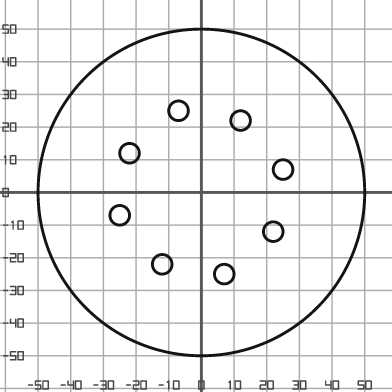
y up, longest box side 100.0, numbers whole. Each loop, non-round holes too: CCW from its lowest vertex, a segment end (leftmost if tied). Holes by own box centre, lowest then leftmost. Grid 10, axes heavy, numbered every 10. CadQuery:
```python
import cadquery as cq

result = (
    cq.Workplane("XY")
    .moveTo(0.0, 0.0)
    .circle(50.0)
    .moveTo(7.0, -25.0)
    .circle(3.0)
    .moveTo(-12.0, -22.0)
    .circle(3.0)
    .moveTo(22.0, -12.0)
    .circle(3.0)
    .moveTo(-25.0, -7.0)
    .circle(3.0)
    .moveTo(25.0, 7.0)
    .circle(3.0)
    .moveTo(-22.0, 12.0)
    .circle(3.0)
    .moveTo(12.0, 22.0)
    .circle(3.0)
    .moveTo(-7.0, 25.0)
    .circle(3.0)
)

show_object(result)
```